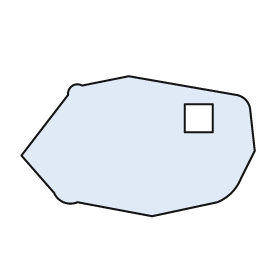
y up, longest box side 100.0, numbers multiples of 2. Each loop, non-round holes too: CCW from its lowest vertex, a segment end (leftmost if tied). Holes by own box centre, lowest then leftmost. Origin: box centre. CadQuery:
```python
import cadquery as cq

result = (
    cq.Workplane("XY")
    .moveTo(6.0, -30.0)
    .lineTo(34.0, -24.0)
    .threePointArc((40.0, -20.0), (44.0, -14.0))
    .lineTo(50.0, -2.0)
    .lineTo(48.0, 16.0)
    .threePointArc((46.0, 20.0), (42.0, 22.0))
    .lineTo(-4.0, 30.0)
    .lineTo(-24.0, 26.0)
    .threePointArc((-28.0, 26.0), (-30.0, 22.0))
    .lineTo(-50.0, -4.0)
    .lineTo(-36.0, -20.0)
    .threePointArc((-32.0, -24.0), (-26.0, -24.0))
    .close()
    .moveTo(20.0, 6.0)
    .lineTo(32.0, 6.0)
    .lineTo(32.0, 18.0)
    .lineTo(20.0, 18.0)
    .close()
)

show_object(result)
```